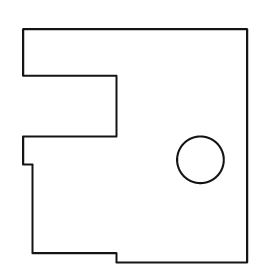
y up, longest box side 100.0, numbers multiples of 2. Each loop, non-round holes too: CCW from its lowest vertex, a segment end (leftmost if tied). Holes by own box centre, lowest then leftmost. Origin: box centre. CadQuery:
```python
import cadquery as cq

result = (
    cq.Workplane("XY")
    .moveTo(-8.0, -50.0)
    .lineTo(48.0, -50.0)
    .lineTo(48.0, 50.0)
    .lineTo(-48.0, 50.0)
    .lineTo(-48.0, 30.0)
    .lineTo(-8.0, 30.0)
    .lineTo(-8.0, 4.0)
    .lineTo(-48.0, 4.0)
    .lineTo(-48.0, -8.0)
    .lineTo(-44.0, -8.0)
    .lineTo(-44.0, -46.0)
    .lineTo(-8.0, -46.0)
    .close()
    .moveTo(28.0, -6.0)
    .circle(10.0)
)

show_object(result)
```